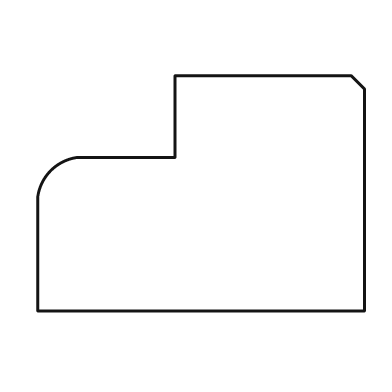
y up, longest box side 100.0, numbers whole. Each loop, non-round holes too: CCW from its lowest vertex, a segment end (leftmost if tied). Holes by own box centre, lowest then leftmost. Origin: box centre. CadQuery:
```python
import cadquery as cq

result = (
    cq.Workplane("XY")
    .moveTo(-50.0, -36.0)
    .lineTo(50.0, -36.0)
    .lineTo(50.0, 32.0)
    .lineTo(46.0, 36.0)
    .lineTo(-8.0, 36.0)
    .lineTo(-8.0, 11.0)
    .lineTo(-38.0, 11.0)
    .threePointArc((-46.0, 7.0), (-50.0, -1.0))
    .close()
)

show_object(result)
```